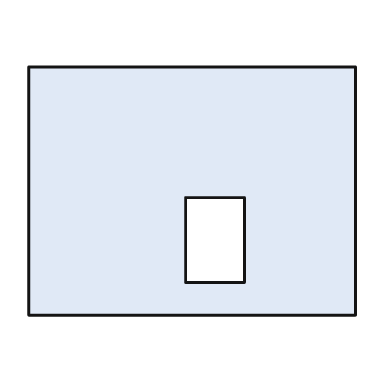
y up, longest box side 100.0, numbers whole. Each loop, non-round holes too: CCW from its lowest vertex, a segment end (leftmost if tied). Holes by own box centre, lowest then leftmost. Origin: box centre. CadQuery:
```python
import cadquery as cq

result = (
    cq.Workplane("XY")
    .moveTo(-50.0, -38.0)
    .lineTo(50.0, -38.0)
    .lineTo(50.0, 38.0)
    .lineTo(-50.0, 38.0)
    .close()
    .moveTo(-2.0, -28.0)
    .lineTo(16.0, -28.0)
    .lineTo(16.0, -2.0)
    .lineTo(-2.0, -2.0)
    .close()
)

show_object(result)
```